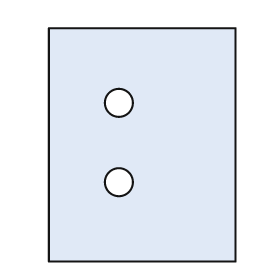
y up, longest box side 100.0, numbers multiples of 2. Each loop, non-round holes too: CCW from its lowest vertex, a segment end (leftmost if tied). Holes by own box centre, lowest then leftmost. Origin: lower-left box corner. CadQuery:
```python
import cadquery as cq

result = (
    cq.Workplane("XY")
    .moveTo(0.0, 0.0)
    .lineTo(80.0, 0.0)
    .lineTo(80.0, 100.0)
    .lineTo(0.0, 100.0)
    .close()
    .moveTo(30.0, 34.0)
    .circle(6.0)
    .moveTo(30.0, 68.0)
    .circle(6.0)
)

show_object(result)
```